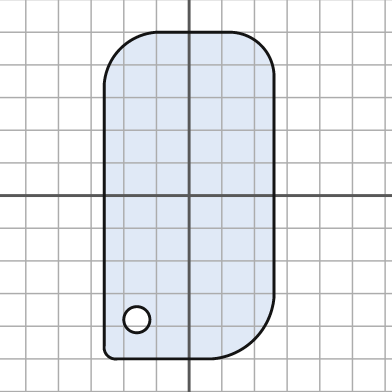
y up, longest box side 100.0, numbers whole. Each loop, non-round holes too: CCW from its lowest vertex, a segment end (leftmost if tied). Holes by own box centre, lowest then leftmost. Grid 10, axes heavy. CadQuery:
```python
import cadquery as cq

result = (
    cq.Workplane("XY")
    .moveTo(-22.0, -50.0)
    .lineTo(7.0, -50.0)
    .threePointArc((20.0, -44.0), (26.0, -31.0))
    .lineTo(26.0, 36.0)
    .threePointArc((22.0, 46.0), (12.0, 50.0))
    .lineTo(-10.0, 50.0)
    .threePointArc((-21.0, 45.0), (-26.0, 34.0))
    .lineTo(-26.0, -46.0)
    .threePointArc((-25.0, -49.0), (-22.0, -50.0))
    .close()
    .moveTo(-16.0, -38.0)
    .circle(4.0)
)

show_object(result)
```